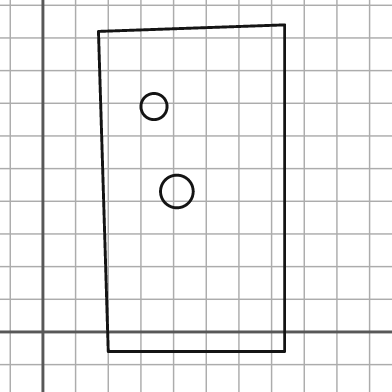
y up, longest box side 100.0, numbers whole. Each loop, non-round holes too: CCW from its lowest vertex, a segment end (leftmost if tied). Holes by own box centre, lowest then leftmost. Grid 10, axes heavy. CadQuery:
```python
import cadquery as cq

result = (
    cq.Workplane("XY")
    .moveTo(20.0, -6.0)
    .lineTo(74.0, -6.0)
    .lineTo(74.0, 94.0)
    .lineTo(17.0, 92.0)
    .close()
    .moveTo(41.0, 43.0)
    .circle(5.0)
    .moveTo(34.0, 69.0)
    .circle(4.0)
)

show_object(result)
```